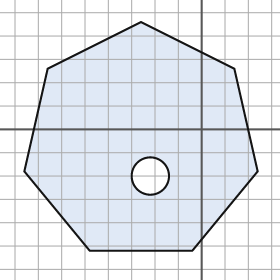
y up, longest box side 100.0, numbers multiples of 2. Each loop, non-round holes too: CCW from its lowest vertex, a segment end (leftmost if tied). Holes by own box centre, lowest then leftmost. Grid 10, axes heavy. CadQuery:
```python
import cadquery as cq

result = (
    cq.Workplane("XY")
    .moveTo(-48.0, -52.0)
    .lineTo(-4.0, -52.0)
    .lineTo(24.0, -18.0)
    .lineTo(14.0, 26.0)
    .lineTo(-26.0, 46.0)
    .lineTo(-66.0, 26.0)
    .lineTo(-76.0, -18.0)
    .close()
    .moveTo(-22.0, -20.0)
    .circle(8.0)
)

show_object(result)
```